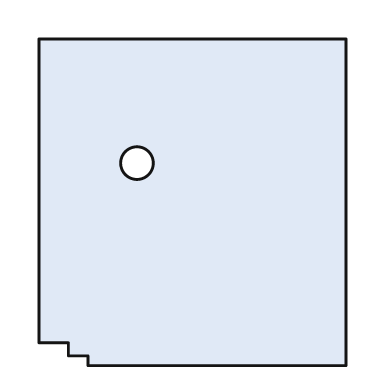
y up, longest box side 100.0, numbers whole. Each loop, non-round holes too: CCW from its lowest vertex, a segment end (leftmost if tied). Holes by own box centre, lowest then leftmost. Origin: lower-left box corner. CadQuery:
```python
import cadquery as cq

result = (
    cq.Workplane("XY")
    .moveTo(15.0, 0.0)
    .lineTo(94.0, 0.0)
    .lineTo(94.0, 100.0)
    .lineTo(0.0, 100.0)
    .lineTo(0.0, 7.0)
    .lineTo(9.0, 7.0)
    .lineTo(9.0, 3.0)
    .lineTo(15.0, 3.0)
    .close()
    .moveTo(30.0, 62.0)
    .circle(5.0)
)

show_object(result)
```